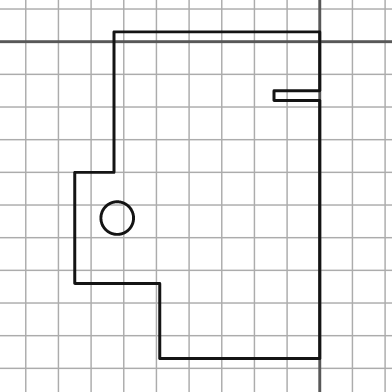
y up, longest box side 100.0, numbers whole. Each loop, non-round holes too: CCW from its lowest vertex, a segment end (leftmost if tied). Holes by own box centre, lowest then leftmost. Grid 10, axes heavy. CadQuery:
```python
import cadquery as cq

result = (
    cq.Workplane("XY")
    .moveTo(-49.0, -97.0)
    .lineTo(0.0, -97.0)
    .lineTo(0.0, -18.0)
    .lineTo(-14.0, -18.0)
    .lineTo(-14.0, -15.0)
    .lineTo(0.0, -15.0)
    .lineTo(0.0, 3.0)
    .lineTo(-63.0, 3.0)
    .lineTo(-63.0, -40.0)
    .lineTo(-75.0, -40.0)
    .lineTo(-75.0, -74.0)
    .lineTo(-49.0, -74.0)
    .close()
    .moveTo(-62.0, -54.0)
    .circle(5.0)
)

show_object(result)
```